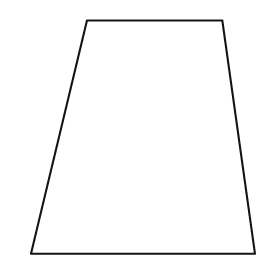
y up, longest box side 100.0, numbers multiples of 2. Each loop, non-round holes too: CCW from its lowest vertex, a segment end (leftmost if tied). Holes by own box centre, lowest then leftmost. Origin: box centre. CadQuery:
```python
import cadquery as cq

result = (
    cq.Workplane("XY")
    .moveTo(-48.0, -50.0)
    .lineTo(48.0, -50.0)
    .lineTo(34.0, 50.0)
    .lineTo(-24.0, 50.0)
    .close()
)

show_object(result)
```